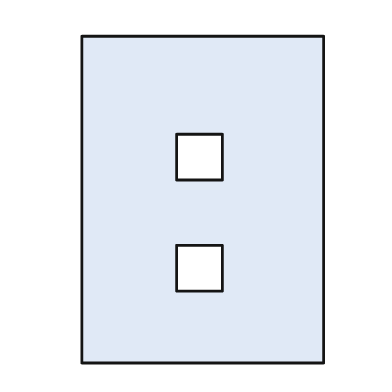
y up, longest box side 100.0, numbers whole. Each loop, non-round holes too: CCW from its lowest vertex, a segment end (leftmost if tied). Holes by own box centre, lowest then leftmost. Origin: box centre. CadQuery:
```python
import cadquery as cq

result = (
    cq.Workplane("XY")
    .moveTo(-37.0, -50.0)
    .lineTo(37.0, -50.0)
    .lineTo(37.0, 50.0)
    .lineTo(-37.0, 50.0)
    .close()
    .moveTo(-8.0, -28.0)
    .lineTo(6.0, -28.0)
    .lineTo(6.0, -14.0)
    .lineTo(-8.0, -14.0)
    .close()
    .moveTo(-8.0, 6.0)
    .lineTo(6.0, 6.0)
    .lineTo(6.0, 20.0)
    .lineTo(-8.0, 20.0)
    .close()
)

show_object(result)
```